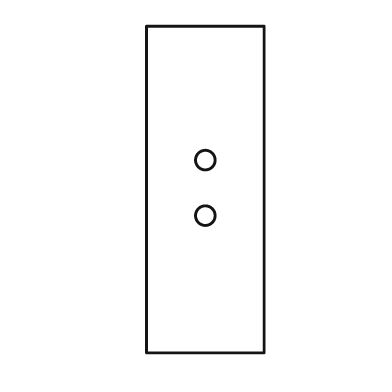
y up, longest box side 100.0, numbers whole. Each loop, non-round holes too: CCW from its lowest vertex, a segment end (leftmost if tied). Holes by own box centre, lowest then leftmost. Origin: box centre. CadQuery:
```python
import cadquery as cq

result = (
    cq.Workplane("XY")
    .moveTo(-18.0, -50.0)
    .lineTo(18.0, -50.0)
    .lineTo(18.0, 50.0)
    .lineTo(-18.0, 50.0)
    .close()
    .moveTo(0.0, -8.0)
    .circle(3.0)
    .moveTo(0.0, 9.0)
    .circle(3.0)
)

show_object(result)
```